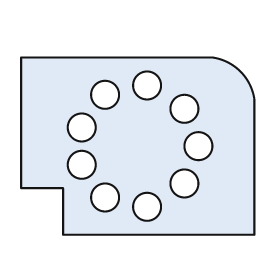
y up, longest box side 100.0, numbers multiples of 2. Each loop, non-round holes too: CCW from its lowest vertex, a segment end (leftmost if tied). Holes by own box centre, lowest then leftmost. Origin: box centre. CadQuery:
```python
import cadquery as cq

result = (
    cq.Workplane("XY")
    .moveTo(-32.0, -38.0)
    .lineTo(50.0, -38.0)
    .lineTo(50.0, 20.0)
    .threePointArc((44.0, 32.0), (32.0, 38.0))
    .lineTo(-50.0, 38.0)
    .lineTo(-50.0, -18.0)
    .lineTo(-32.0, -18.0)
    .close()
    .moveTo(4.0, -26.0)
    .circle(6.0)
    .moveTo(-14.0, -22.0)
    .circle(6.0)
    .moveTo(20.0, -16.0)
    .circle(6.0)
    .moveTo(-24.0, -8.0)
    .circle(6.0)
    .moveTo(26.0, 0.0)
    .circle(6.0)
    .moveTo(-24.0, 8.0)
    .circle(6.0)
    .moveTo(20.0, 16.0)
    .circle(6.0)
    .moveTo(-14.0, 22.0)
    .circle(6.0)
    .moveTo(4.0, 26.0)
    .circle(6.0)
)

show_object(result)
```